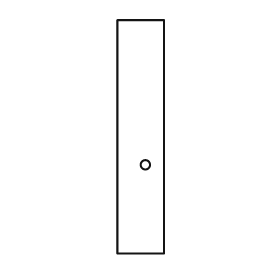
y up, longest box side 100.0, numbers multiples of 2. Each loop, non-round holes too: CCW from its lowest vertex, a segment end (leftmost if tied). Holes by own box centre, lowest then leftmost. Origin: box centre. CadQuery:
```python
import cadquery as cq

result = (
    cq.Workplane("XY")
    .moveTo(-10.0, -50.0)
    .lineTo(10.0, -50.0)
    .lineTo(10.0, 50.0)
    .lineTo(-10.0, 50.0)
    .close()
    .moveTo(2.0, -12.0)
    .circle(2.0)
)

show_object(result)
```